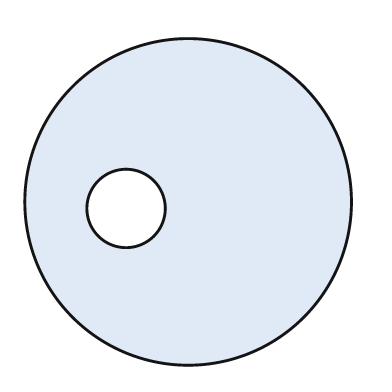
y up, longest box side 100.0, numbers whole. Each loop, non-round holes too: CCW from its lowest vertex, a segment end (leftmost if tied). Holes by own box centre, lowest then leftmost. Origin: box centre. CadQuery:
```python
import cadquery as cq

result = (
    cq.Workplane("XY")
    .moveTo(0.0, 0.0)
    .circle(50.0)
    .moveTo(-19.0, -2.0)
    .circle(12.0)
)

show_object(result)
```